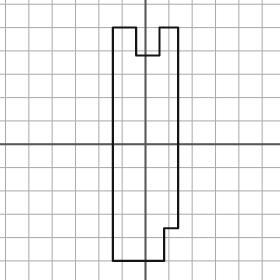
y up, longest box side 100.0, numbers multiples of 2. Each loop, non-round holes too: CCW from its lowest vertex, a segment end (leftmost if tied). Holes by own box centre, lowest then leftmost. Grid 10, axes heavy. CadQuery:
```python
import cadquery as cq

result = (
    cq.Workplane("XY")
    .moveTo(-14.0, -50.0)
    .lineTo(8.0, -50.0)
    .lineTo(8.0, -36.0)
    .lineTo(14.0, -36.0)
    .lineTo(14.0, 50.0)
    .lineTo(6.0, 50.0)
    .lineTo(6.0, 38.0)
    .lineTo(-4.0, 38.0)
    .lineTo(-4.0, 50.0)
    .lineTo(-14.0, 50.0)
    .close()
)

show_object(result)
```